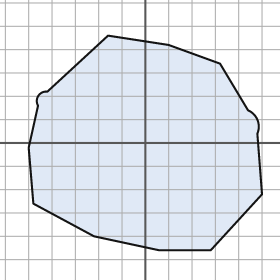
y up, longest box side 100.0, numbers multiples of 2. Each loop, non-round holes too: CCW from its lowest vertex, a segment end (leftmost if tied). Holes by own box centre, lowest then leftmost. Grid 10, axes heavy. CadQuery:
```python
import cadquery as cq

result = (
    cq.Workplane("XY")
    .moveTo(6.0, -46.0)
    .lineTo(28.0, -46.0)
    .lineTo(50.0, -22.0)
    .lineTo(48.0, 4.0)
    .threePointArc((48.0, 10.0), (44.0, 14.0))
    .lineTo(32.0, 34.0)
    .lineTo(10.0, 42.0)
    .lineTo(-16.0, 46.0)
    .lineTo(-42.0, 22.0)
    .threePointArc((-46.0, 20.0), (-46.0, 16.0))
    .lineTo(-50.0, -2.0)
    .lineTo(-48.0, -26.0)
    .lineTo(-22.0, -40.0)
    .close()
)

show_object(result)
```